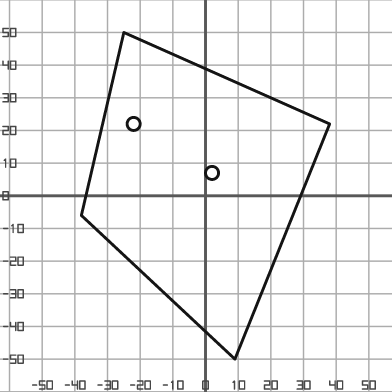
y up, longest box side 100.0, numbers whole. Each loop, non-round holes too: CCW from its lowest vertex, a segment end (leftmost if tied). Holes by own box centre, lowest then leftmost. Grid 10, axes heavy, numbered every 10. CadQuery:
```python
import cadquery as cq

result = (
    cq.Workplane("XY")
    .moveTo(9.0, -50.0)
    .lineTo(38.0, 22.0)
    .lineTo(-25.0, 50.0)
    .lineTo(-38.0, -6.0)
    .close()
    .moveTo(2.0, 7.0)
    .circle(2.0)
    .moveTo(-22.0, 22.0)
    .circle(2.0)
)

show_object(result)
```